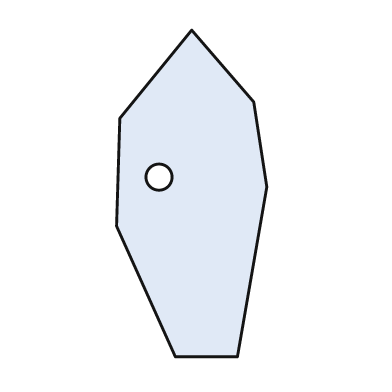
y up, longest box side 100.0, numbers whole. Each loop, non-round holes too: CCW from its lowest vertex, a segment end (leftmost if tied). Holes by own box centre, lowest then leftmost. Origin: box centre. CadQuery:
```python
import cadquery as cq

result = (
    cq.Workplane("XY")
    .moveTo(-5.0, -50.0)
    .lineTo(14.0, -50.0)
    .lineTo(23.0, 2.0)
    .lineTo(19.0, 28.0)
    .lineTo(0.0, 50.0)
    .lineTo(-22.0, 23.0)
    .lineTo(-23.0, -10.0)
    .close()
    .moveTo(-10.0, 5.0)
    .circle(4.0)
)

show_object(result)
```